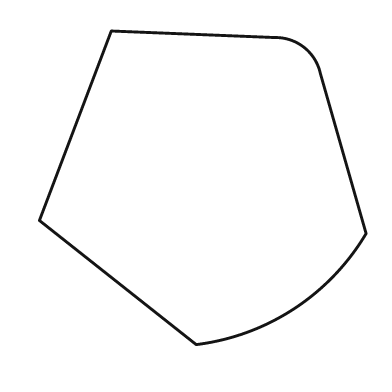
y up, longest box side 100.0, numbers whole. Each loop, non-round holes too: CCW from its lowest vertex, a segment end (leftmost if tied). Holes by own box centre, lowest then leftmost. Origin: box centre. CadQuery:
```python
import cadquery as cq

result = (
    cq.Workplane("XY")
    .moveTo(-2.0, -48.0)
    .threePointArc((28.0, -37.0), (50.0, -14.0))
    .lineTo(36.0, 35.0)
    .threePointArc((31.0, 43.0), (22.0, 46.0))
    .lineTo(-28.0, 48.0)
    .lineTo(-50.0, -10.0)
    .close()
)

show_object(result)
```